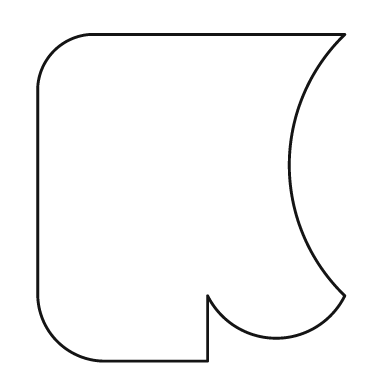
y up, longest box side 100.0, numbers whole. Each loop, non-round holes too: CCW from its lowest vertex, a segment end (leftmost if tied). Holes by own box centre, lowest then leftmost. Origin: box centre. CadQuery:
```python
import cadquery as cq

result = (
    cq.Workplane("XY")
    .moveTo(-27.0, -50.0)
    .lineTo(5.0, -50.0)
    .lineTo(5.0, -30.0)
    .threePointArc((26.0, -43.0), (47.0, -30.0))
    .threePointArc((30.0, 10.0), (47.0, 50.0))
    .lineTo(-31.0, 50.0)
    .threePointArc((-42.0, 45.0), (-47.0, 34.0))
    .lineTo(-47.0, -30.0)
    .threePointArc((-41.0, -44.0), (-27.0, -50.0))
    .close()
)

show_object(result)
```